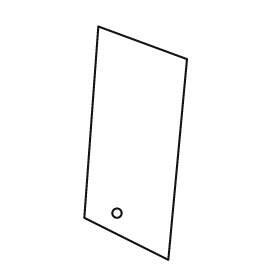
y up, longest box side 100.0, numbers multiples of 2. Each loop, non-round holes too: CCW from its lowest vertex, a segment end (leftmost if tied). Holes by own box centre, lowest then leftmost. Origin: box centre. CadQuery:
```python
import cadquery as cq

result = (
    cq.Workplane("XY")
    .moveTo(14.0, -50.0)
    .lineTo(22.0, 36.0)
    .lineTo(-16.0, 50.0)
    .lineTo(-22.0, -32.0)
    .close()
    .moveTo(-8.0, -30.0)
    .circle(2.0)
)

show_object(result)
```